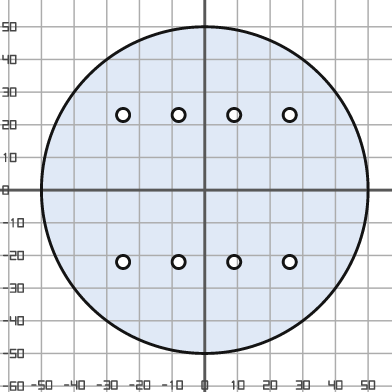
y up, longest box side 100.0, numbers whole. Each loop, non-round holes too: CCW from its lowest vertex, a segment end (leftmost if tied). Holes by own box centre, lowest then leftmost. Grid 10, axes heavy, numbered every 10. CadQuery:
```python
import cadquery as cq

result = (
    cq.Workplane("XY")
    .moveTo(0.0, 0.0)
    .circle(50.0)
    .moveTo(-25.0, -22.0)
    .circle(2.0)
    .moveTo(-8.0, -22.0)
    .circle(2.0)
    .moveTo(9.0, -22.0)
    .circle(2.0)
    .moveTo(26.0, -22.0)
    .circle(2.0)
    .moveTo(-25.0, 23.0)
    .circle(2.0)
    .moveTo(-8.0, 23.0)
    .circle(2.0)
    .moveTo(9.0, 23.0)
    .circle(2.0)
    .moveTo(26.0, 23.0)
    .circle(2.0)
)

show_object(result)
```